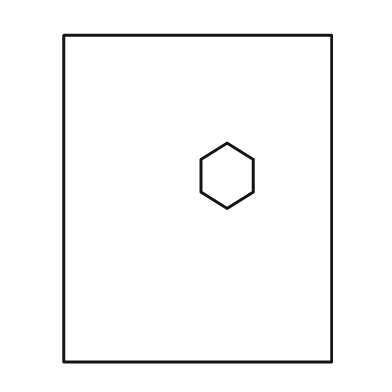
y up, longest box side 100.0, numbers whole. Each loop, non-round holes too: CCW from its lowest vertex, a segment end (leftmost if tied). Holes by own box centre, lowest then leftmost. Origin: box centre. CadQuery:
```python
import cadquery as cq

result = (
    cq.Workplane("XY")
    .moveTo(-41.0, -50.0)
    .lineTo(41.0, -50.0)
    .lineTo(41.0, 50.0)
    .lineTo(-41.0, 50.0)
    .close()
    .moveTo(9.0, -3.0)
    .lineTo(17.0, 2.0)
    .lineTo(17.0, 12.0)
    .lineTo(9.0, 17.0)
    .lineTo(1.0, 12.0)
    .lineTo(1.0, 2.0)
    .close()
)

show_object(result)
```